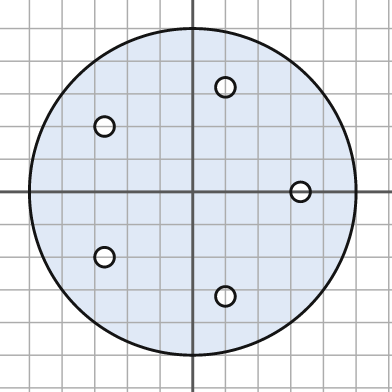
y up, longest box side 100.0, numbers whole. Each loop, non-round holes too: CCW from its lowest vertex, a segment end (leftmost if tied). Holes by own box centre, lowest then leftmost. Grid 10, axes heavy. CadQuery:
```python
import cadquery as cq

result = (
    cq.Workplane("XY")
    .moveTo(0.0, 0.0)
    .circle(50.0)
    .moveTo(10.0, -32.0)
    .circle(3.0)
    .moveTo(-27.0, -20.0)
    .circle(3.0)
    .moveTo(33.0, 0.0)
    .circle(3.0)
    .moveTo(-27.0, 20.0)
    .circle(3.0)
    .moveTo(10.0, 32.0)
    .circle(3.0)
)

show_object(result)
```